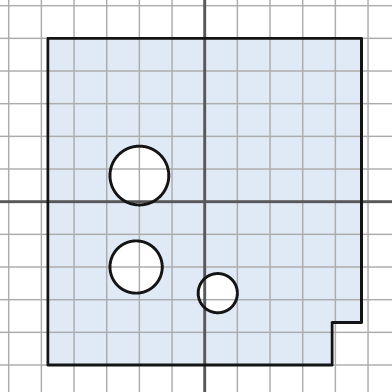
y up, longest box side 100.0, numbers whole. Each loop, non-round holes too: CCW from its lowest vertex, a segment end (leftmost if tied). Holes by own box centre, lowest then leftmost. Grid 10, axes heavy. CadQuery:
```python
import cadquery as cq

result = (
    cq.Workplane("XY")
    .moveTo(-48.0, -50.0)
    .lineTo(39.0, -50.0)
    .lineTo(39.0, -37.0)
    .lineTo(48.0, -37.0)
    .lineTo(48.0, 50.0)
    .lineTo(-48.0, 50.0)
    .close()
    .moveTo(4.0, -28.0)
    .circle(6.0)
    .moveTo(-21.0, -20.0)
    .circle(8.0)
    .moveTo(-20.0, 8.0)
    .circle(9.0)
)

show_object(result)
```